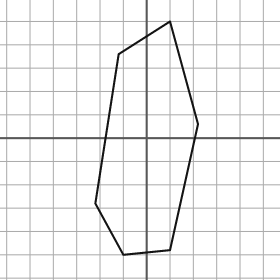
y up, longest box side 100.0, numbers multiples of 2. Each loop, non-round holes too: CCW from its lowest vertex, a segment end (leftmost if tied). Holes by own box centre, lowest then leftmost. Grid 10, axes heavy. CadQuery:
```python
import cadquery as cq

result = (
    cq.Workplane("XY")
    .moveTo(-10.0, -50.0)
    .lineTo(10.0, -48.0)
    .lineTo(22.0, 6.0)
    .lineTo(10.0, 50.0)
    .lineTo(-12.0, 36.0)
    .lineTo(-22.0, -28.0)
    .close()
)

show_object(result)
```